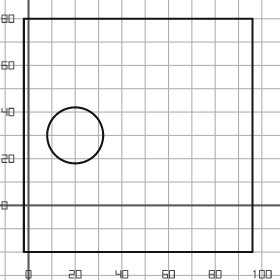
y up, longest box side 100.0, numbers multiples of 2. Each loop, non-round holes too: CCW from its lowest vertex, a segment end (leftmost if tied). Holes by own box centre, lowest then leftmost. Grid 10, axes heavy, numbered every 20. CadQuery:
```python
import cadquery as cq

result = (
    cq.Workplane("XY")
    .moveTo(-2.0, -20.0)
    .lineTo(96.0, -20.0)
    .lineTo(96.0, 80.0)
    .lineTo(-2.0, 80.0)
    .close()
    .moveTo(20.0, 30.0)
    .circle(12.0)
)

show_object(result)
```